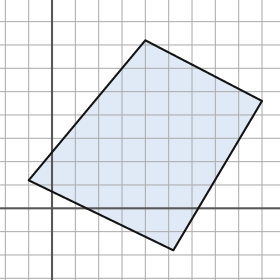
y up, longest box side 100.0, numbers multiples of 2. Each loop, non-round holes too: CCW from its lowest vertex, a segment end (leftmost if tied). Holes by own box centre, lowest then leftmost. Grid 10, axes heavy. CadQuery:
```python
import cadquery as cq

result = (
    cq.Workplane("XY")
    .moveTo(52.0, -18.0)
    .lineTo(90.0, 46.0)
    .lineTo(40.0, 72.0)
    .lineTo(-10.0, 12.0)
    .close()
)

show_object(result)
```